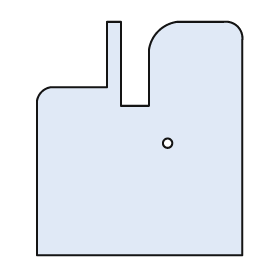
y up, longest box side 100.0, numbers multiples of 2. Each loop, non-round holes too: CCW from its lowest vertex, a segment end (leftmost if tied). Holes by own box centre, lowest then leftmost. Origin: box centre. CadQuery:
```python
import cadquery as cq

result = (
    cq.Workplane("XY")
    .moveTo(-44.0, -50.0)
    .lineTo(44.0, -50.0)
    .lineTo(44.0, 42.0)
    .threePointArc((42.0, 48.0), (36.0, 50.0))
    .lineTo(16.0, 50.0)
    .threePointArc((8.0, 46.0), (4.0, 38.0))
    .lineTo(4.0, 14.0)
    .lineTo(-8.0, 14.0)
    .lineTo(-8.0, 50.0)
    .lineTo(-14.0, 50.0)
    .lineTo(-14.0, 22.0)
    .lineTo(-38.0, 22.0)
    .threePointArc((-42.0, 20.0), (-44.0, 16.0))
    .close()
    .moveTo(12.0, -2.0)
    .circle(2.0)
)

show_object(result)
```